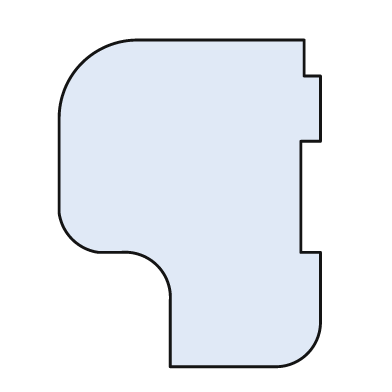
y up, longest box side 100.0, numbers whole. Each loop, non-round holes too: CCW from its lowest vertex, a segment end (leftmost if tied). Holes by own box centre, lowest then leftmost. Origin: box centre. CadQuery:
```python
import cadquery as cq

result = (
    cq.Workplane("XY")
    .moveTo(-6.0, -50.0)
    .lineTo(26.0, -50.0)
    .threePointArc((36.0, -46.0), (40.0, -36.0))
    .lineTo(40.0, -15.0)
    .lineTo(34.0, -15.0)
    .lineTo(34.0, 19.0)
    .lineTo(40.0, 19.0)
    .lineTo(40.0, 39.0)
    .lineTo(35.0, 39.0)
    .lineTo(35.0, 50.0)
    .lineTo(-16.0, 50.0)
    .threePointArc((-33.0, 43.0), (-40.0, 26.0))
    .lineTo(-40.0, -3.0)
    .threePointArc((-36.0, -11.0), (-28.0, -15.0))
    .lineTo(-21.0, -15.0)
    .threePointArc((-10.0, -19.0), (-6.0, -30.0))
    .close()
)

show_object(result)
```